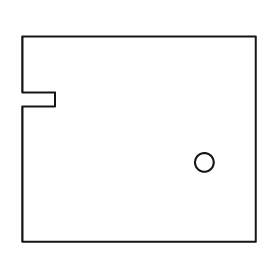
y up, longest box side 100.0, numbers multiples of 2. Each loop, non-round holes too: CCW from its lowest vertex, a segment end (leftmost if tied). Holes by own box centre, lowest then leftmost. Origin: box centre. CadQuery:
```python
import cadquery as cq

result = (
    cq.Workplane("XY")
    .moveTo(-50.0, -44.0)
    .lineTo(50.0, -44.0)
    .lineTo(50.0, 44.0)
    .lineTo(-50.0, 44.0)
    .lineTo(-50.0, 20.0)
    .lineTo(-36.0, 20.0)
    .lineTo(-36.0, 14.0)
    .lineTo(-50.0, 14.0)
    .close()
    .moveTo(28.0, -10.0)
    .circle(4.0)
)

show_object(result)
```